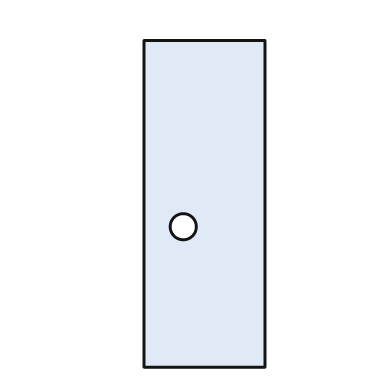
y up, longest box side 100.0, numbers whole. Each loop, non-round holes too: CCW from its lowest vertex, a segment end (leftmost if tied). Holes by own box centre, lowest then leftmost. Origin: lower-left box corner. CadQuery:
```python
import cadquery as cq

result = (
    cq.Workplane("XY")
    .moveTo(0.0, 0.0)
    .lineTo(37.0, 0.0)
    .lineTo(37.0, 100.0)
    .lineTo(0.0, 100.0)
    .close()
    .moveTo(12.0, 43.0)
    .circle(4.0)
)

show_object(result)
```